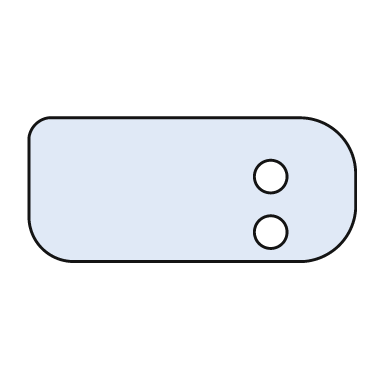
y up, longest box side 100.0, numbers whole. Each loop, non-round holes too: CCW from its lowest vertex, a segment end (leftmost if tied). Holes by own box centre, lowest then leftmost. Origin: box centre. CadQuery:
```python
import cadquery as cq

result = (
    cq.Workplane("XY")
    .moveTo(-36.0, -22.0)
    .lineTo(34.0, -22.0)
    .threePointArc((45.0, -17.0), (50.0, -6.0))
    .lineTo(50.0, 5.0)
    .threePointArc((45.0, 17.0), (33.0, 22.0))
    .lineTo(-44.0, 22.0)
    .threePointArc((-48.0, 20.0), (-50.0, 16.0))
    .lineTo(-50.0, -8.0)
    .threePointArc((-46.0, -18.0), (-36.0, -22.0))
    .close()
    .moveTo(24.0, -13.0)
    .circle(5.0)
    .moveTo(24.0, 4.0)
    .circle(5.0)
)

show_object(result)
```